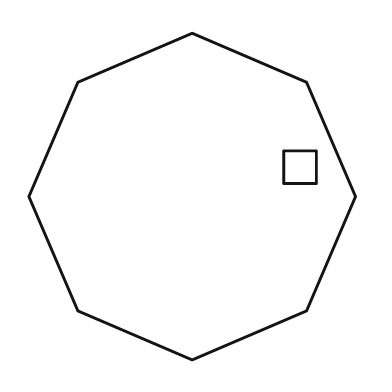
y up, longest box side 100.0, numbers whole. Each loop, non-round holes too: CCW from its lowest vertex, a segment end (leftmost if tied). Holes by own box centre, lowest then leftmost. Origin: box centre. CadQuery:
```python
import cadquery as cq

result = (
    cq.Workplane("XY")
    .moveTo(0.0, -50.0)
    .lineTo(35.0, -35.0)
    .lineTo(50.0, 0.0)
    .lineTo(35.0, 35.0)
    .lineTo(0.0, 50.0)
    .lineTo(-35.0, 35.0)
    .lineTo(-50.0, 0.0)
    .lineTo(-35.0, -35.0)
    .close()
    .moveTo(28.0, 4.0)
    .lineTo(38.0, 4.0)
    .lineTo(38.0, 14.0)
    .lineTo(28.0, 14.0)
    .close()
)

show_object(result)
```